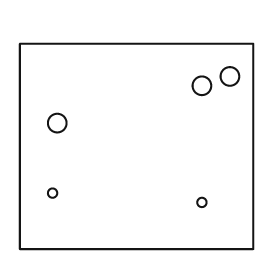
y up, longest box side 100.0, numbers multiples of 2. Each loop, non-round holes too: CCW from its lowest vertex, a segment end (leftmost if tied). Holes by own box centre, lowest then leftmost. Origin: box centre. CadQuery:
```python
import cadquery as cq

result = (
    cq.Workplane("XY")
    .moveTo(-50.0, -44.0)
    .lineTo(50.0, -44.0)
    .lineTo(50.0, 44.0)
    .lineTo(-50.0, 44.0)
    .close()
    .moveTo(28.0, -24.0)
    .circle(2.0)
    .moveTo(-36.0, -20.0)
    .circle(2.0)
    .moveTo(-34.0, 10.0)
    .circle(4.0)
    .moveTo(28.0, 26.0)
    .circle(4.0)
    .moveTo(40.0, 30.0)
    .circle(4.0)
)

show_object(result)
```